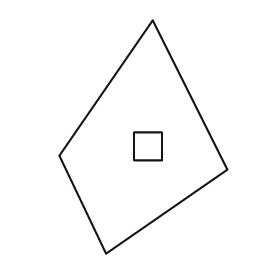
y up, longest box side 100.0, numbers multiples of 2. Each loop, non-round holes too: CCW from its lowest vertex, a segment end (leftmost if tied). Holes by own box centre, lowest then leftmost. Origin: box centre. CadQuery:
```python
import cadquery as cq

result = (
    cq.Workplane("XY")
    .moveTo(-16.0, -50.0)
    .lineTo(36.0, -14.0)
    .lineTo(4.0, 50.0)
    .lineTo(-36.0, -8.0)
    .close()
    .moveTo(-4.0, -10.0)
    .lineTo(8.0, -10.0)
    .lineTo(8.0, 2.0)
    .lineTo(-4.0, 2.0)
    .close()
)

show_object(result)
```